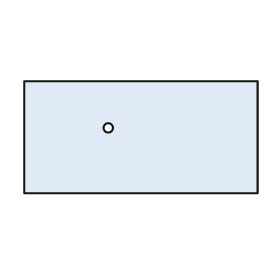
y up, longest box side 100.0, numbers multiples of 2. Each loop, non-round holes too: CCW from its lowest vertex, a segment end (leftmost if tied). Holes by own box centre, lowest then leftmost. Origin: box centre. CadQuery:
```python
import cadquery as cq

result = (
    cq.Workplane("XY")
    .moveTo(-50.0, -24.0)
    .lineTo(50.0, -24.0)
    .lineTo(50.0, 24.0)
    .lineTo(-50.0, 24.0)
    .close()
    .moveTo(-14.0, 4.0)
    .circle(2.0)
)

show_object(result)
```